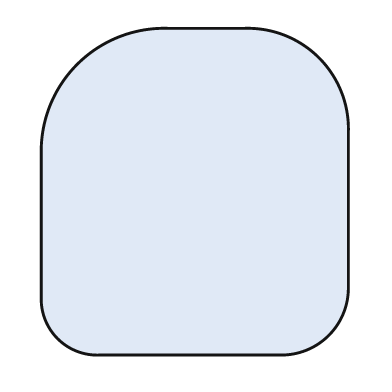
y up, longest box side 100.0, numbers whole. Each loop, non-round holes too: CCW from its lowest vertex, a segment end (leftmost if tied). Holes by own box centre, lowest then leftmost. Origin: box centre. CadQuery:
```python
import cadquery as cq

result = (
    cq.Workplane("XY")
    .moveTo(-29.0, -50.0)
    .lineTo(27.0, -50.0)
    .threePointArc((41.0, -44.0), (47.0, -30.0))
    .lineTo(47.0, 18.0)
    .threePointArc((38.0, 41.0), (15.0, 50.0))
    .lineTo(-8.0, 50.0)
    .threePointArc((-36.0, 39.0), (-47.0, 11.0))
    .lineTo(-47.0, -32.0)
    .threePointArc((-42.0, -45.0), (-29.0, -50.0))
    .close()
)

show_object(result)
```